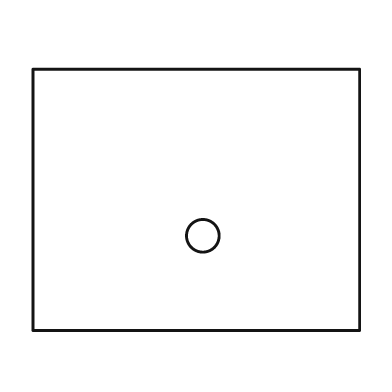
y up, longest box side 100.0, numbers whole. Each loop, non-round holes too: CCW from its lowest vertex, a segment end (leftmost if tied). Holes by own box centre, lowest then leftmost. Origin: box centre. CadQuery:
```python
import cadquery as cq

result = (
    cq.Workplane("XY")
    .moveTo(-50.0, -40.0)
    .lineTo(50.0, -40.0)
    .lineTo(50.0, 40.0)
    .lineTo(-50.0, 40.0)
    .close()
    .moveTo(2.0, -11.0)
    .circle(5.0)
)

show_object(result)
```